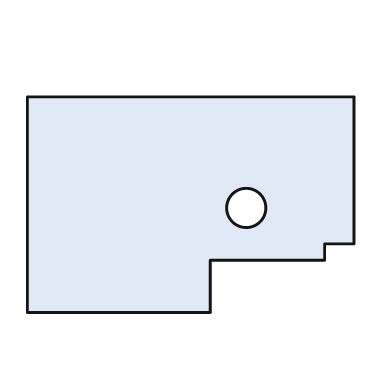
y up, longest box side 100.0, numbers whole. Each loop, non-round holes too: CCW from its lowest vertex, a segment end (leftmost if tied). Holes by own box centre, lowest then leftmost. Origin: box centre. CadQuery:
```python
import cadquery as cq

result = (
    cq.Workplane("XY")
    .moveTo(-50.0, -33.0)
    .lineTo(6.0, -33.0)
    .lineTo(6.0, -17.0)
    .lineTo(41.0, -17.0)
    .lineTo(41.0, -12.0)
    .lineTo(50.0, -12.0)
    .lineTo(50.0, 33.0)
    .lineTo(-50.0, 33.0)
    .close()
    .moveTo(17.0, -1.0)
    .circle(6.0)
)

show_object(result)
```